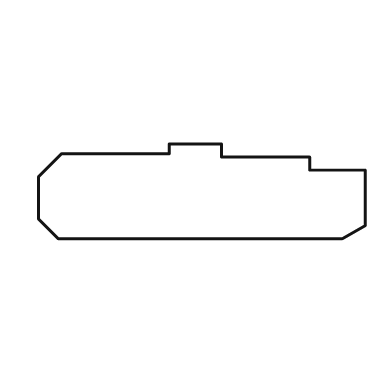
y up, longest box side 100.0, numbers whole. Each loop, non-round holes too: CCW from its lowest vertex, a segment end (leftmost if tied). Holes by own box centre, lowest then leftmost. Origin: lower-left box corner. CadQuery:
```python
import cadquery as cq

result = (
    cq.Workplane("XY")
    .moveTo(6.0, 0.0)
    .lineTo(93.0, 0.0)
    .lineTo(100.0, 4.0)
    .lineTo(100.0, 21.0)
    .lineTo(83.0, 21.0)
    .lineTo(83.0, 25.0)
    .lineTo(56.0, 25.0)
    .lineTo(56.0, 29.0)
    .lineTo(40.0, 29.0)
    .lineTo(40.0, 26.0)
    .lineTo(7.0, 26.0)
    .lineTo(0.0, 19.0)
    .lineTo(0.0, 6.0)
    .close()
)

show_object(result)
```